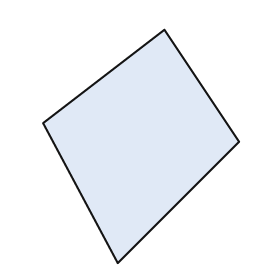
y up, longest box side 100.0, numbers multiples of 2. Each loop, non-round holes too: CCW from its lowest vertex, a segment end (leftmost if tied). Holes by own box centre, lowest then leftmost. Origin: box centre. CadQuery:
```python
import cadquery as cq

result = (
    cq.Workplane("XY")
    .moveTo(-10.0, -50.0)
    .lineTo(42.0, 2.0)
    .lineTo(10.0, 50.0)
    .lineTo(-42.0, 10.0)
    .close()
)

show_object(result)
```